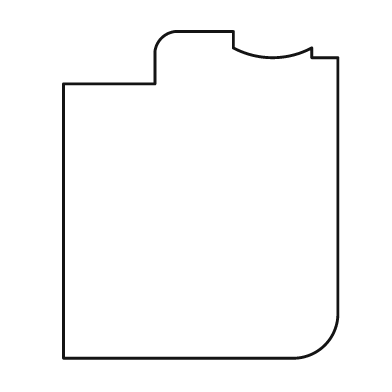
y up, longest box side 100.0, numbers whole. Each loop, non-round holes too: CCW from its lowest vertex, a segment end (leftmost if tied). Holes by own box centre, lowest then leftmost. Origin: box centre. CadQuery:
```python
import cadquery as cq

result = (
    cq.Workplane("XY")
    .moveTo(-42.0, -50.0)
    .lineTo(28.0, -50.0)
    .threePointArc((38.0, -46.0), (42.0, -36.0))
    .lineTo(42.0, 42.0)
    .lineTo(34.0, 42.0)
    .lineTo(34.0, 45.0)
    .threePointArc((22.0, 42.0), (10.0, 45.0))
    .lineTo(10.0, 50.0)
    .lineTo(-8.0, 50.0)
    .threePointArc((-12.0, 48.0), (-14.0, 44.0))
    .lineTo(-14.0, 34.0)
    .lineTo(-42.0, 34.0)
    .close()
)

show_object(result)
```